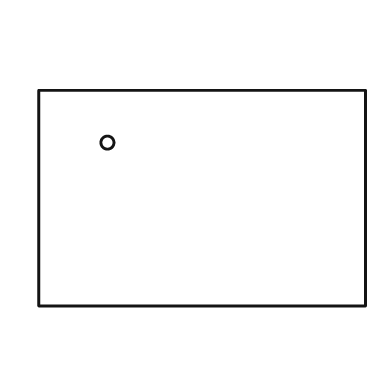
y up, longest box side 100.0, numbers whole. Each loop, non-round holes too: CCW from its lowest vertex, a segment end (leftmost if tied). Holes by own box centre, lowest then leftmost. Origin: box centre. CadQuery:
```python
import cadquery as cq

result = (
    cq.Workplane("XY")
    .moveTo(-50.0, -33.0)
    .lineTo(50.0, -33.0)
    .lineTo(50.0, 33.0)
    .lineTo(-50.0, 33.0)
    .close()
    .moveTo(-29.0, 17.0)
    .circle(2.0)
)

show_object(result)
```